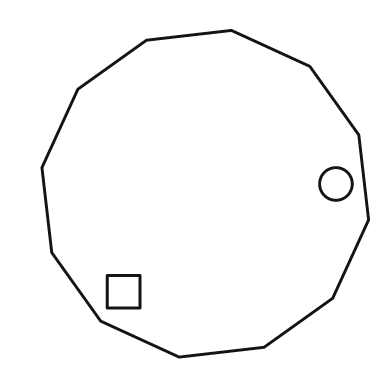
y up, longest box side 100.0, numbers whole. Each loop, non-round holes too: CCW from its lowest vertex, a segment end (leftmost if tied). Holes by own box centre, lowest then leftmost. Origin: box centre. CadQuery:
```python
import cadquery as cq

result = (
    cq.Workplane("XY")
    .moveTo(-8.0, -50.0)
    .lineTo(18.0, -47.0)
    .lineTo(39.0, -32.0)
    .lineTo(50.0, -8.0)
    .lineTo(47.0, 18.0)
    .lineTo(32.0, 39.0)
    .lineTo(8.0, 50.0)
    .lineTo(-18.0, 47.0)
    .lineTo(-39.0, 32.0)
    .lineTo(-50.0, 8.0)
    .lineTo(-47.0, -18.0)
    .lineTo(-32.0, -39.0)
    .close()
    .moveTo(-30.0, -35.0)
    .lineTo(-20.0, -35.0)
    .lineTo(-20.0, -25.0)
    .lineTo(-30.0, -25.0)
    .close()
    .moveTo(40.0, 3.0)
    .circle(5.0)
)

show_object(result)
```